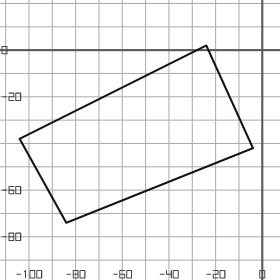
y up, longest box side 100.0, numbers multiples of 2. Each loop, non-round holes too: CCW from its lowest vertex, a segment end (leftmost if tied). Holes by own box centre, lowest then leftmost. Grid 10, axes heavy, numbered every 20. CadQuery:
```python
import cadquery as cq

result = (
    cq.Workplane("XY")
    .moveTo(-84.0, -74.0)
    .lineTo(-4.0, -42.0)
    .lineTo(-24.0, 2.0)
    .lineTo(-104.0, -38.0)
    .close()
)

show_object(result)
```